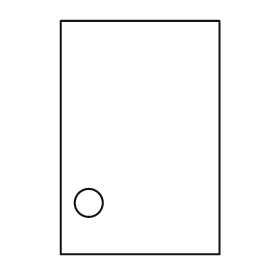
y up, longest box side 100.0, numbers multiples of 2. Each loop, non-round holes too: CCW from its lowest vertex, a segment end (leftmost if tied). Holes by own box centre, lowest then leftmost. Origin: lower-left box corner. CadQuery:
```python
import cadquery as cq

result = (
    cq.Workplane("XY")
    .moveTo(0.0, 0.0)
    .lineTo(68.0, 0.0)
    .lineTo(68.0, 100.0)
    .lineTo(0.0, 100.0)
    .close()
    .moveTo(12.0, 22.0)
    .circle(6.0)
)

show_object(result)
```